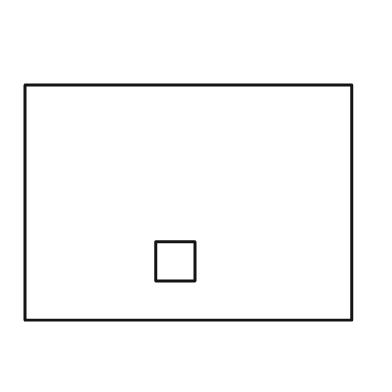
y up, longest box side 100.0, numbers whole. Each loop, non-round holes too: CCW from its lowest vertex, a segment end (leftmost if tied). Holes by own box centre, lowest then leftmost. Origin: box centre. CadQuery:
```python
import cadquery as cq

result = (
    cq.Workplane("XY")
    .moveTo(-50.0, -36.0)
    .lineTo(50.0, -36.0)
    .lineTo(50.0, 36.0)
    .lineTo(-50.0, 36.0)
    .close()
    .moveTo(-10.0, -24.0)
    .lineTo(2.0, -24.0)
    .lineTo(2.0, -12.0)
    .lineTo(-10.0, -12.0)
    .close()
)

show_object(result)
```